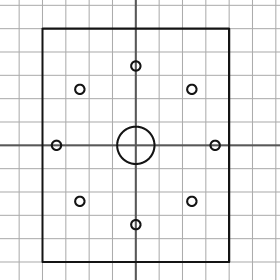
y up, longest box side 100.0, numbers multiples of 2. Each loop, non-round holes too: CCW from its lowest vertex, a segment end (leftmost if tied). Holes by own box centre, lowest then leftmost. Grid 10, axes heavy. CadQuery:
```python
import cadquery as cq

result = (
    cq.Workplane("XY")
    .moveTo(-40.0, -50.0)
    .lineTo(40.0, -50.0)
    .lineTo(40.0, 50.0)
    .lineTo(-40.0, 50.0)
    .close()
    .moveTo(0.0, -34.0)
    .circle(2.0)
    .moveTo(-24.0, -24.0)
    .circle(2.0)
    .moveTo(24.0, -24.0)
    .circle(2.0)
    .moveTo(-34.0, 0.0)
    .circle(2.0)
    .moveTo(0.0, 0.0)
    .circle(8.0)
    .moveTo(34.0, 0.0)
    .circle(2.0)
    .moveTo(-24.0, 24.0)
    .circle(2.0)
    .moveTo(24.0, 24.0)
    .circle(2.0)
    .moveTo(0.0, 34.0)
    .circle(2.0)
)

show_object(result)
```